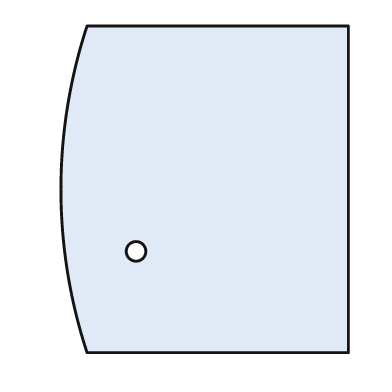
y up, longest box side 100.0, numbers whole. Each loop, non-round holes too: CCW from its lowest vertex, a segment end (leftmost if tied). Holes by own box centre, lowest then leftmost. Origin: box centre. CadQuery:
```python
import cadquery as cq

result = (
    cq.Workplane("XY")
    .moveTo(-36.0, -50.0)
    .lineTo(44.0, -50.0)
    .lineTo(44.0, 50.0)
    .lineTo(-36.0, 50.0)
    .threePointArc((-44.0, 0.0), (-36.0, -50.0))
    .close()
    .moveTo(-21.0, -19.0)
    .circle(3.0)
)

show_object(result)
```